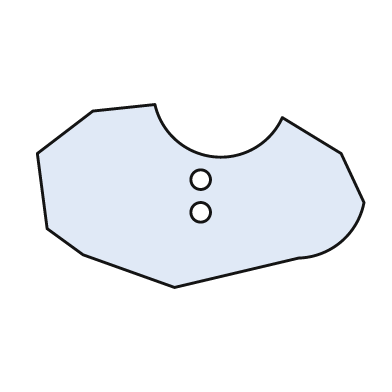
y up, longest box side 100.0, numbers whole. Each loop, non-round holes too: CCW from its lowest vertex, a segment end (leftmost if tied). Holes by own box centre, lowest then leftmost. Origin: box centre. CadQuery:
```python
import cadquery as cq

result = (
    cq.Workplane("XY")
    .moveTo(-8.0, -28.0)
    .lineTo(30.0, -19.0)
    .threePointArc((43.0, -14.0), (50.0, -2.0))
    .lineTo(43.0, 13.0)
    .lineTo(25.0, 24.0)
    .threePointArc((4.0, 12.0), (-14.0, 28.0))
    .lineTo(-33.0, 26.0)
    .lineTo(-50.0, 13.0)
    .lineTo(-47.0, -10.0)
    .lineTo(-36.0, -18.0)
    .close()
    .moveTo(0.0, -5.0)
    .circle(3.0)
    .moveTo(0.0, 5.0)
    .circle(3.0)
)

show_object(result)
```